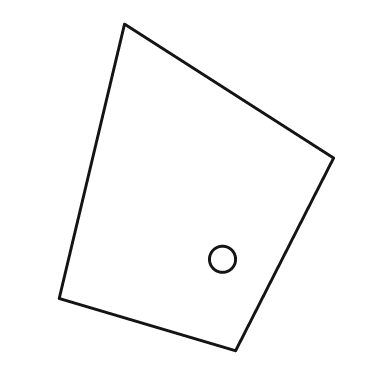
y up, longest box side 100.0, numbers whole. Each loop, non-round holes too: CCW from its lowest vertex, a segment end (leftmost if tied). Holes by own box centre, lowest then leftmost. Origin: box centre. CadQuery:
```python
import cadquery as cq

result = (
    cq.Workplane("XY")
    .moveTo(12.0, -50.0)
    .lineTo(42.0, 9.0)
    .lineTo(-22.0, 50.0)
    .lineTo(-42.0, -34.0)
    .close()
    .moveTo(8.0, -22.0)
    .circle(4.0)
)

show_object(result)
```